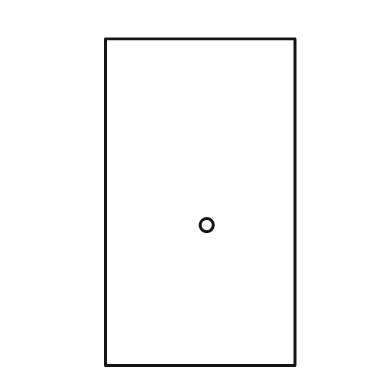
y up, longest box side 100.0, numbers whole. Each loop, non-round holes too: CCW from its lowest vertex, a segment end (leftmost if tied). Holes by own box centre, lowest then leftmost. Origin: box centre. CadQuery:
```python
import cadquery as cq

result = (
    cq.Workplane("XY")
    .moveTo(-29.0, -50.0)
    .lineTo(29.0, -50.0)
    .lineTo(29.0, 50.0)
    .lineTo(-29.0, 50.0)
    .close()
    .moveTo(2.0, -7.0)
    .circle(2.0)
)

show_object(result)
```